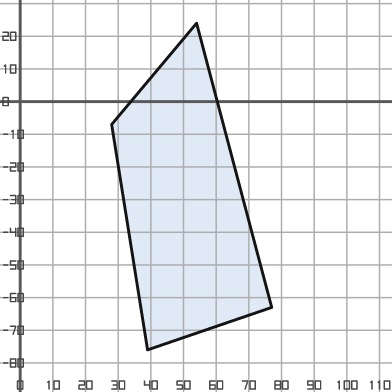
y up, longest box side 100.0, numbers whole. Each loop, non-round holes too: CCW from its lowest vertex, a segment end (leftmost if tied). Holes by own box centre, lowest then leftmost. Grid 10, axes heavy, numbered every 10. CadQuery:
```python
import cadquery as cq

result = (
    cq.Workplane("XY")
    .moveTo(39.0, -76.0)
    .lineTo(77.0, -63.0)
    .lineTo(54.0, 24.0)
    .lineTo(28.0, -7.0)
    .close()
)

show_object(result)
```